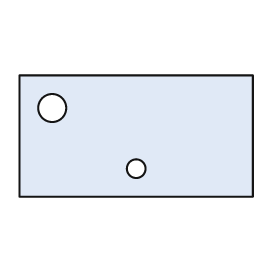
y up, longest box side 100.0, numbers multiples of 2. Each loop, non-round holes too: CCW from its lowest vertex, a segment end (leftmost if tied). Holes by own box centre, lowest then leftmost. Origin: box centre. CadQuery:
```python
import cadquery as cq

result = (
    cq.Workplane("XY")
    .moveTo(-50.0, -26.0)
    .lineTo(50.0, -26.0)
    .lineTo(50.0, 26.0)
    .lineTo(-50.0, 26.0)
    .close()
    .moveTo(0.0, -14.0)
    .circle(4.0)
    .moveTo(-36.0, 12.0)
    .circle(6.0)
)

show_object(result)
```